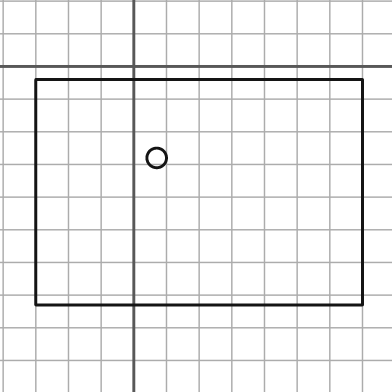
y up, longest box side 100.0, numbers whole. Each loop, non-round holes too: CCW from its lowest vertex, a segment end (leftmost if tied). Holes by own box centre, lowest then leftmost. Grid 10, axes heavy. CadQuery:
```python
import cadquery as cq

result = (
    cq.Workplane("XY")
    .moveTo(-30.0, -73.0)
    .lineTo(70.0, -73.0)
    .lineTo(70.0, -4.0)
    .lineTo(-30.0, -4.0)
    .close()
    .moveTo(7.0, -28.0)
    .circle(3.0)
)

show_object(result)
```